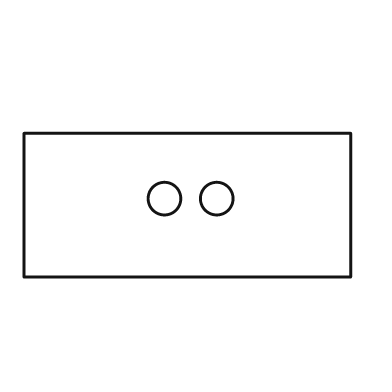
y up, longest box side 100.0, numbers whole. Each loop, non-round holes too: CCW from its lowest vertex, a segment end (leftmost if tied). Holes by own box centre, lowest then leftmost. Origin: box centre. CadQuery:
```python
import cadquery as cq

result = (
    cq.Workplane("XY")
    .moveTo(-50.0, -22.0)
    .lineTo(50.0, -22.0)
    .lineTo(50.0, 22.0)
    .lineTo(-50.0, 22.0)
    .close()
    .moveTo(-7.0, 2.0)
    .circle(5.0)
    .moveTo(9.0, 2.0)
    .circle(5.0)
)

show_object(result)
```